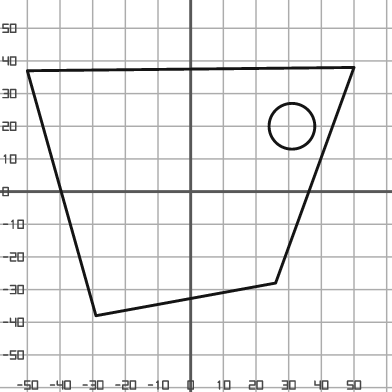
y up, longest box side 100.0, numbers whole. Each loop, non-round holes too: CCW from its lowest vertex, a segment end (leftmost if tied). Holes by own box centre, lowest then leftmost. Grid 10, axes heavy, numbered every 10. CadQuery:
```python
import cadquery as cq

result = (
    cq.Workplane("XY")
    .moveTo(-29.0, -38.0)
    .lineTo(26.0, -28.0)
    .lineTo(50.0, 38.0)
    .lineTo(-50.0, 37.0)
    .close()
    .moveTo(31.0, 20.0)
    .circle(7.0)
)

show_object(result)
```